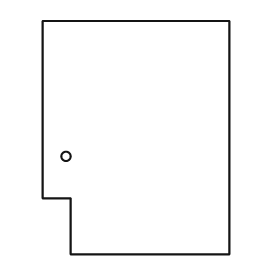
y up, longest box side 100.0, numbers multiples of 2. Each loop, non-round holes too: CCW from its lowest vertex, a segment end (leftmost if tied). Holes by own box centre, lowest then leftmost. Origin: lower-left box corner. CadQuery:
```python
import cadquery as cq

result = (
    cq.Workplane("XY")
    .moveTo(12.0, 0.0)
    .lineTo(80.0, 0.0)
    .lineTo(80.0, 100.0)
    .lineTo(0.0, 100.0)
    .lineTo(0.0, 24.0)
    .lineTo(12.0, 24.0)
    .close()
    .moveTo(10.0, 42.0)
    .circle(2.0)
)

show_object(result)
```